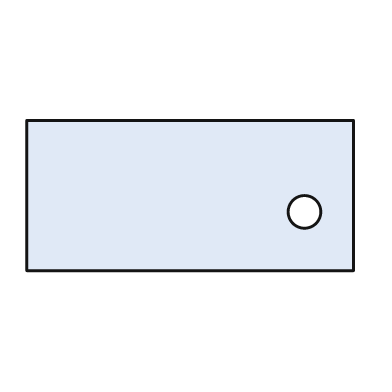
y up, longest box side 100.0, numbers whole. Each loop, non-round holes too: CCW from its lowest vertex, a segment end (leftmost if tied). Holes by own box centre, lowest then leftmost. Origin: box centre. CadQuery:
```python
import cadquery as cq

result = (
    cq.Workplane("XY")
    .moveTo(-50.0, -23.0)
    .lineTo(50.0, -23.0)
    .lineTo(50.0, 23.0)
    .lineTo(-50.0, 23.0)
    .close()
    .moveTo(35.0, -5.0)
    .circle(5.0)
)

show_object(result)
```